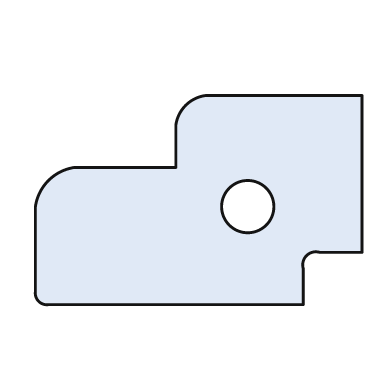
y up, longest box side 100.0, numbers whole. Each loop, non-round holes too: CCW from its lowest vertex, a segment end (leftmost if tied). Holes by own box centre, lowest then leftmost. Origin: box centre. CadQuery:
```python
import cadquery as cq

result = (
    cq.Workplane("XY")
    .moveTo(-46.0, -32.0)
    .lineTo(32.0, -32.0)
    .lineTo(32.0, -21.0)
    .threePointArc((33.0, -17.0), (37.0, -16.0))
    .lineTo(50.0, -16.0)
    .lineTo(50.0, 32.0)
    .lineTo(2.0, 32.0)
    .threePointArc((-4.0, 29.0), (-7.0, 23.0))
    .lineTo(-7.0, 10.0)
    .lineTo(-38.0, 10.0)
    .threePointArc((-46.0, 6.0), (-50.0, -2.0))
    .lineTo(-50.0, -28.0)
    .threePointArc((-49.0, -31.0), (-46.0, -32.0))
    .close()
    .moveTo(15.0, -2.0)
    .circle(8.0)
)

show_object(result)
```